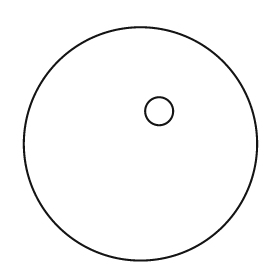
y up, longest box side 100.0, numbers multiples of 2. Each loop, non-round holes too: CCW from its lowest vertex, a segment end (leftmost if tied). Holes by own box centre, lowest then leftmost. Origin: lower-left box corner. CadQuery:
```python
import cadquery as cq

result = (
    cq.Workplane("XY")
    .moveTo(50.0, 50.0)
    .circle(50.0)
    .moveTo(58.0, 64.0)
    .circle(6.0)
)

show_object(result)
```